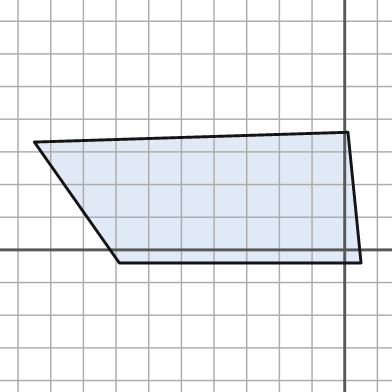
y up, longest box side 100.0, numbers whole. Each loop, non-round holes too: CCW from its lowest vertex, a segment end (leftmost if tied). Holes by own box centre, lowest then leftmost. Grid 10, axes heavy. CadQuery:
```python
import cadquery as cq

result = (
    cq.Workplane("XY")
    .moveTo(-69.0, -4.0)
    .lineTo(5.0, -4.0)
    .lineTo(1.0, 36.0)
    .lineTo(-95.0, 33.0)
    .close()
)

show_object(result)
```